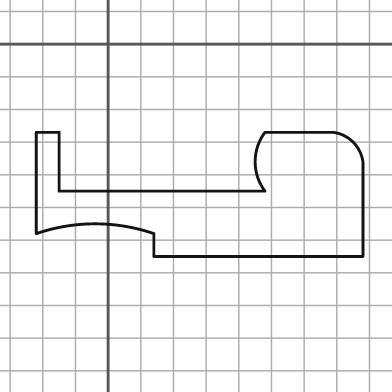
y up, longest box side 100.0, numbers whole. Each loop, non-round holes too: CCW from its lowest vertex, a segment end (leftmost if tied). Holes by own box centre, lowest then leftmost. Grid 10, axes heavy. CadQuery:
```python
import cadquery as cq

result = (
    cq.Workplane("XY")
    .moveTo(14.0, -65.0)
    .lineTo(78.0, -65.0)
    .lineTo(78.0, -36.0)
    .threePointArc((75.0, -30.0), (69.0, -27.0))
    .lineTo(48.0, -27.0)
    .threePointArc((45.0, -36.0), (48.0, -45.0))
    .lineTo(-15.0, -45.0)
    .lineTo(-15.0, -27.0)
    .lineTo(-22.0, -27.0)
    .lineTo(-22.0, -58.0)
    .threePointArc((-4.0, -55.0), (14.0, -58.0))
    .close()
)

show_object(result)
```